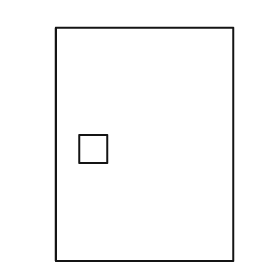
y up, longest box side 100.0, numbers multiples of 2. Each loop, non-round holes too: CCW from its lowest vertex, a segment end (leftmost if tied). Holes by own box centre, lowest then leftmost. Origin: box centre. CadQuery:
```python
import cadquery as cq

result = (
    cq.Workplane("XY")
    .moveTo(-38.0, -50.0)
    .lineTo(38.0, -50.0)
    .lineTo(38.0, 50.0)
    .lineTo(-38.0, 50.0)
    .close()
    .moveTo(-28.0, -8.0)
    .lineTo(-16.0, -8.0)
    .lineTo(-16.0, 4.0)
    .lineTo(-28.0, 4.0)
    .close()
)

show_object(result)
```